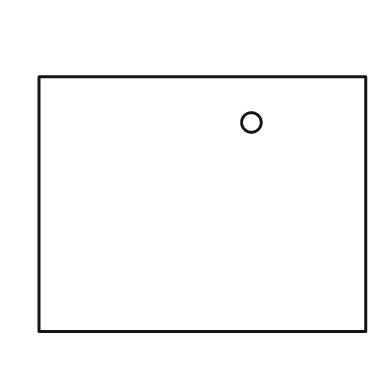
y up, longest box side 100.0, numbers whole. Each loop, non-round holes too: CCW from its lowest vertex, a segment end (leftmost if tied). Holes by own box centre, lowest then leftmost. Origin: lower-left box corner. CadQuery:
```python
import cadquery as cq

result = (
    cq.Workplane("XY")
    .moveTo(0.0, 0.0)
    .lineTo(100.0, 0.0)
    .lineTo(100.0, 78.0)
    .lineTo(0.0, 78.0)
    .close()
    .moveTo(65.0, 64.0)
    .circle(3.0)
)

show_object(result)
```